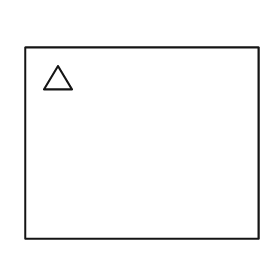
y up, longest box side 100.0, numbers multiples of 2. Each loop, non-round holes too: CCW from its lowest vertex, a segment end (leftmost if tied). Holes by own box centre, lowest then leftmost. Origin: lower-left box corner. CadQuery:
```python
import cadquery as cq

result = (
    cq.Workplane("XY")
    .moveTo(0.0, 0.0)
    .lineTo(100.0, 0.0)
    .lineTo(100.0, 82.0)
    .lineTo(0.0, 82.0)
    .close()
    .moveTo(8.0, 64.0)
    .lineTo(20.0, 64.0)
    .lineTo(14.0, 74.0)
    .close()
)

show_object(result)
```